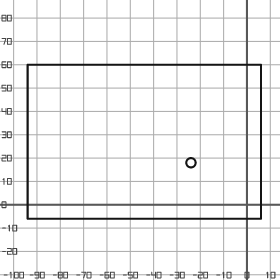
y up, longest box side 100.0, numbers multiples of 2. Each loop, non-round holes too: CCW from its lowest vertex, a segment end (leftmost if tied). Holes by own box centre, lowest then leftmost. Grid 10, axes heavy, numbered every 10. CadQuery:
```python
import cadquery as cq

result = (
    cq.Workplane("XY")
    .moveTo(-94.0, -6.0)
    .lineTo(6.0, -6.0)
    .lineTo(6.0, 60.0)
    .lineTo(-94.0, 60.0)
    .close()
    .moveTo(-24.0, 18.0)
    .circle(2.0)
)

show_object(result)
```